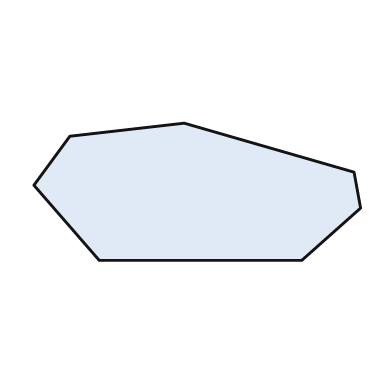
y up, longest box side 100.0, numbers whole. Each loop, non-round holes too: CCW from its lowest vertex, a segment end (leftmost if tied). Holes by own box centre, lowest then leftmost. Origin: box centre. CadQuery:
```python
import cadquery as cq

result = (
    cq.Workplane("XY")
    .moveTo(-30.0, -21.0)
    .lineTo(32.0, -21.0)
    .lineTo(50.0, -5.0)
    .lineTo(48.0, 6.0)
    .lineTo(-4.0, 21.0)
    .lineTo(-39.0, 17.0)
    .lineTo(-50.0, 2.0)
    .close()
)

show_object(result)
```